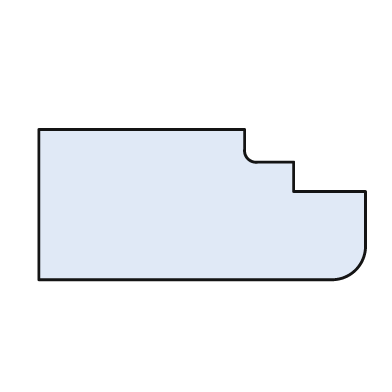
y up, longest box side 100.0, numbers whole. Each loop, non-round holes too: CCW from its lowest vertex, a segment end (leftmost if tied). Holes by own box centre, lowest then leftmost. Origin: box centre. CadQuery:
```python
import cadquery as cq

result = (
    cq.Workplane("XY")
    .moveTo(-50.0, -23.0)
    .lineTo(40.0, -23.0)
    .threePointArc((47.0, -20.0), (50.0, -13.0))
    .lineTo(50.0, 4.0)
    .lineTo(28.0, 4.0)
    .lineTo(28.0, 13.0)
    .lineTo(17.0, 13.0)
    .threePointArc((14.0, 14.0), (13.0, 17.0))
    .lineTo(13.0, 23.0)
    .lineTo(-50.0, 23.0)
    .close()
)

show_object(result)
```